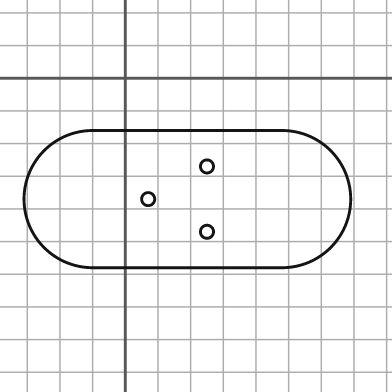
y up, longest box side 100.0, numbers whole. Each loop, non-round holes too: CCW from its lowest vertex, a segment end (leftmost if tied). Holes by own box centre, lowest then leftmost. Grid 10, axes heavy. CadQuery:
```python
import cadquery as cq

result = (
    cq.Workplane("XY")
    .moveTo(-10.0, -58.0)
    .lineTo(48.0, -58.0)
    .threePointArc((69.0, -37.0), (48.0, -16.0))
    .lineTo(-10.0, -16.0)
    .threePointArc((-31.0, -37.0), (-10.0, -58.0))
    .close()
    .moveTo(25.0, -47.0)
    .circle(2.0)
    .moveTo(7.0, -37.0)
    .circle(2.0)
    .moveTo(25.0, -27.0)
    .circle(2.0)
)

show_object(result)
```